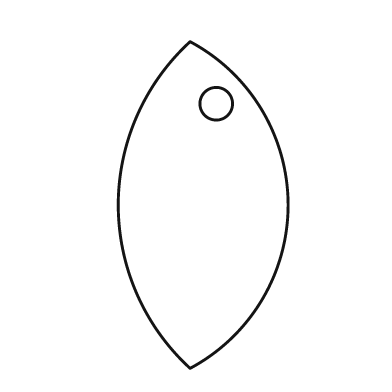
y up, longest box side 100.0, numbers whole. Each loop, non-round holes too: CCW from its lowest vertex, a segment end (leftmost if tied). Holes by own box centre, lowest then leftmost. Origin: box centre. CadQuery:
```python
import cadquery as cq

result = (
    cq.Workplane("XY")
    .moveTo(-4.0, -50.0)
    .threePointArc((26.0, 0.0), (-4.0, 50.0))
    .threePointArc((-26.0, 0.0), (-4.0, -50.0))
    .close()
    .moveTo(4.0, 31.0)
    .circle(5.0)
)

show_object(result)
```